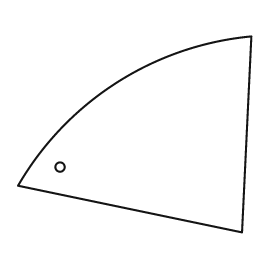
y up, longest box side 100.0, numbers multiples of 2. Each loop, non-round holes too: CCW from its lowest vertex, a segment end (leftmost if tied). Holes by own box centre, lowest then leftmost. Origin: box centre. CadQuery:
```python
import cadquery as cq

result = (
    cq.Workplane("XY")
    .moveTo(46.0, -42.0)
    .lineTo(50.0, 42.0)
    .threePointArc((-8.0, 22.0), (-50.0, -22.0))
    .close()
    .moveTo(-32.0, -14.0)
    .circle(2.0)
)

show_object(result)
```